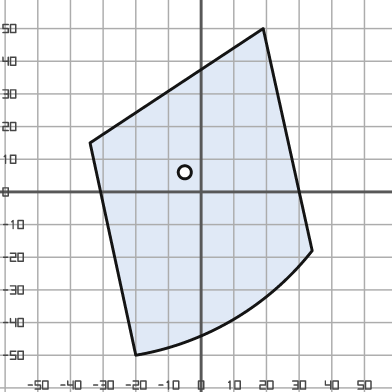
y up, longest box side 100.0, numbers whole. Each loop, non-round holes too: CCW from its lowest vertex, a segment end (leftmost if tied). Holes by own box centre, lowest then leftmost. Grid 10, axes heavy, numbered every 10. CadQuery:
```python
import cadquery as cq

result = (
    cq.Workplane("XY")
    .moveTo(-20.0, -50.0)
    .threePointArc((10.0, -39.0), (34.0, -18.0))
    .lineTo(19.0, 50.0)
    .lineTo(-34.0, 15.0)
    .close()
    .moveTo(-5.0, 6.0)
    .circle(2.0)
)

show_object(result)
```